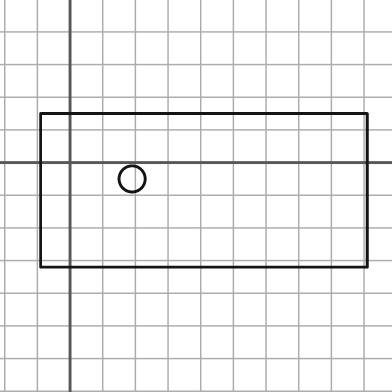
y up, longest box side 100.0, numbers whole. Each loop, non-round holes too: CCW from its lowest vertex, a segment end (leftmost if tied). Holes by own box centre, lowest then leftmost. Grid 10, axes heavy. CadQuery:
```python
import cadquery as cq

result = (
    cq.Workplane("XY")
    .moveTo(-9.0, -32.0)
    .lineTo(91.0, -32.0)
    .lineTo(91.0, 15.0)
    .lineTo(-9.0, 15.0)
    .close()
    .moveTo(19.0, -5.0)
    .circle(4.0)
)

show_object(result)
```